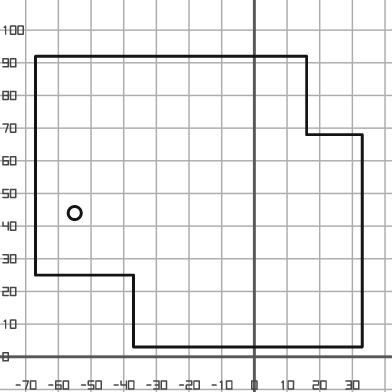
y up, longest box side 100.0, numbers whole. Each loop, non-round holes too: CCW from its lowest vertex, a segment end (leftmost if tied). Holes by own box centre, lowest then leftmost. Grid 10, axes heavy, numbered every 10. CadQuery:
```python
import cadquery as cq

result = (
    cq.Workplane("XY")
    .moveTo(-37.0, 3.0)
    .lineTo(33.0, 3.0)
    .lineTo(33.0, 68.0)
    .lineTo(16.0, 68.0)
    .lineTo(16.0, 92.0)
    .lineTo(-67.0, 92.0)
    .lineTo(-67.0, 25.0)
    .lineTo(-37.0, 25.0)
    .close()
    .moveTo(-55.0, 44.0)
    .circle(2.0)
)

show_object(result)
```